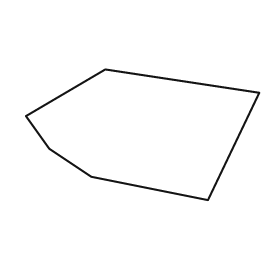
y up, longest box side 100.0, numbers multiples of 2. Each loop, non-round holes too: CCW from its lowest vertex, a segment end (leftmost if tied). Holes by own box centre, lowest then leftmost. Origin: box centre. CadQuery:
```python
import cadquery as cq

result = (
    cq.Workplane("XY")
    .moveTo(28.0, -28.0)
    .lineTo(50.0, 18.0)
    .lineTo(-16.0, 28.0)
    .lineTo(-50.0, 8.0)
    .lineTo(-40.0, -6.0)
    .lineTo(-22.0, -18.0)
    .close()
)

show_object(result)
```